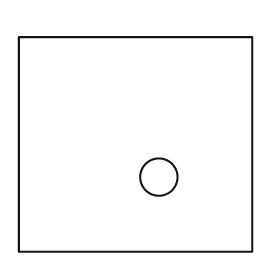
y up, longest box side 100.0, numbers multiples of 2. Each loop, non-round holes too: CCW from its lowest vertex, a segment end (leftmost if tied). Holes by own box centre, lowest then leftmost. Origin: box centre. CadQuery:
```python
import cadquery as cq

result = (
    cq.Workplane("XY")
    .moveTo(-50.0, -46.0)
    .lineTo(50.0, -46.0)
    .lineTo(50.0, 46.0)
    .lineTo(-50.0, 46.0)
    .close()
    .moveTo(10.0, -14.0)
    .circle(8.0)
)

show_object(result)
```